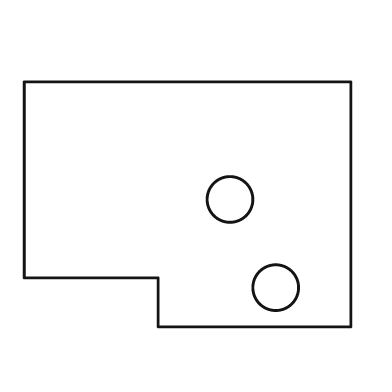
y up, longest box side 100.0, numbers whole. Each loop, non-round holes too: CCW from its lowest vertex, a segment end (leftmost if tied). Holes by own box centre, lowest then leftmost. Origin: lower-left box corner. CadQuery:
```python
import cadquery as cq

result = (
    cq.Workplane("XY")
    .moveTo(41.0, 0.0)
    .lineTo(100.0, 0.0)
    .lineTo(100.0, 75.0)
    .lineTo(0.0, 75.0)
    .lineTo(0.0, 15.0)
    .lineTo(41.0, 15.0)
    .close()
    .moveTo(77.0, 12.0)
    .circle(7.0)
    .moveTo(63.0, 39.0)
    .circle(7.0)
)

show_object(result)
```